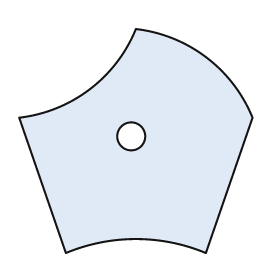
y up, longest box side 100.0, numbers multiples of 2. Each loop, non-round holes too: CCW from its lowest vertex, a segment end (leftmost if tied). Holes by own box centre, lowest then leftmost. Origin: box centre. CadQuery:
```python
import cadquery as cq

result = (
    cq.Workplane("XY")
    .moveTo(-30.0, -48.0)
    .threePointArc((0.0, -42.0), (30.0, -48.0))
    .lineTo(50.0, 10.0)
    .threePointArc((30.0, 36.0), (0.0, 48.0))
    .threePointArc((-20.0, 22.0), (-50.0, 10.0))
    .close()
    .moveTo(-2.0, 2.0)
    .circle(6.0)
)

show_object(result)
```